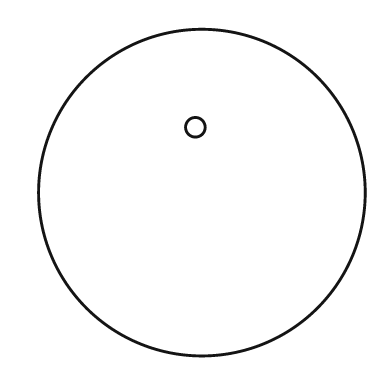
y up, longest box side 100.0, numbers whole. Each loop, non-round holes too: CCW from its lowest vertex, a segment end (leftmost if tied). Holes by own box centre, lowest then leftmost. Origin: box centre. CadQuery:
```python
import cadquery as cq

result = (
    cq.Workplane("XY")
    .moveTo(0.0, 0.0)
    .circle(50.0)
    .moveTo(-2.0, 20.0)
    .circle(3.0)
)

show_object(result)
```